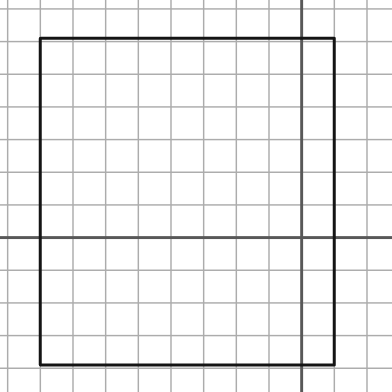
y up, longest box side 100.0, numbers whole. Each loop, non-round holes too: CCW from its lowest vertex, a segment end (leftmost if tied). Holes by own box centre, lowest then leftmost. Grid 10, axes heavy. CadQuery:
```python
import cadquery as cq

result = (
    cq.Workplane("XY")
    .moveTo(-80.0, -39.0)
    .lineTo(10.0, -39.0)
    .lineTo(10.0, 61.0)
    .lineTo(-80.0, 61.0)
    .close()
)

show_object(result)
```